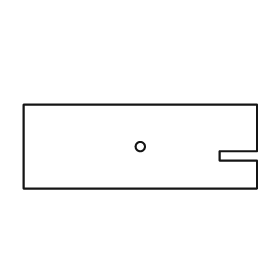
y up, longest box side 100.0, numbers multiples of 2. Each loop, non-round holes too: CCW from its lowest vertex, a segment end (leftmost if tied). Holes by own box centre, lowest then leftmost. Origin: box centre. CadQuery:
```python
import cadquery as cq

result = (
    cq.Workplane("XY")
    .moveTo(-50.0, -18.0)
    .lineTo(50.0, -18.0)
    .lineTo(50.0, -6.0)
    .lineTo(34.0, -6.0)
    .lineTo(34.0, -2.0)
    .lineTo(50.0, -2.0)
    .lineTo(50.0, 18.0)
    .lineTo(-50.0, 18.0)
    .close()
    .moveTo(0.0, 0.0)
    .circle(2.0)
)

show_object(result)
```